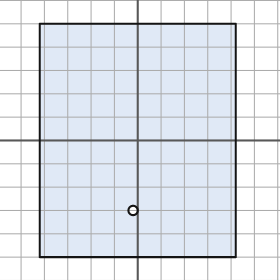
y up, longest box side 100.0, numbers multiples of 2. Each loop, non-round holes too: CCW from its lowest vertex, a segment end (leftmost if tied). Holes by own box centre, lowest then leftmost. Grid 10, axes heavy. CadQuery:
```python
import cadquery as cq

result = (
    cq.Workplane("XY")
    .moveTo(-42.0, -50.0)
    .lineTo(42.0, -50.0)
    .lineTo(42.0, 50.0)
    .lineTo(-42.0, 50.0)
    .close()
    .moveTo(-2.0, -30.0)
    .circle(2.0)
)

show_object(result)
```